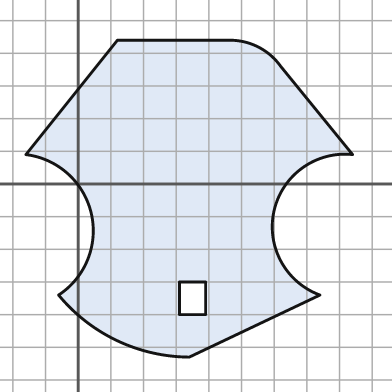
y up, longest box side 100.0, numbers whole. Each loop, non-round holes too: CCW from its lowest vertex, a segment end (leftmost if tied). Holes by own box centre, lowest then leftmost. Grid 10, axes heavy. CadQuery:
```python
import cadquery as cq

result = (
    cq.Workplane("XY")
    .moveTo(34.0, -53.0)
    .lineTo(74.0, -34.0)
    .threePointArc((60.0, -8.0), (84.0, 9.0))
    .lineTo(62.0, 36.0)
    .threePointArc((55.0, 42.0), (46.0, 44.0))
    .lineTo(12.0, 44.0)
    .lineTo(-16.0, 9.0)
    .threePointArc((4.0, -9.0), (-6.0, -34.0))
    .threePointArc((12.0, -48.0), (34.0, -53.0))
    .close()
    .moveTo(31.0, -40.0)
    .lineTo(39.0, -40.0)
    .lineTo(39.0, -30.0)
    .lineTo(31.0, -30.0)
    .close()
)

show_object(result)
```